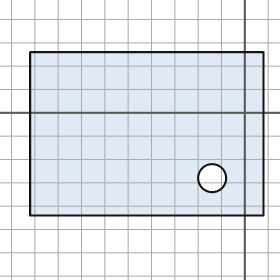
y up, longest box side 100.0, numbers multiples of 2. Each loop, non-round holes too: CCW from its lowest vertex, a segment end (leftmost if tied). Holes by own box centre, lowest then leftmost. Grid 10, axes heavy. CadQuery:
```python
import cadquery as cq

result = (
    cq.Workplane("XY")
    .moveTo(-92.0, -44.0)
    .lineTo(8.0, -44.0)
    .lineTo(8.0, 26.0)
    .lineTo(-92.0, 26.0)
    .close()
    .moveTo(-14.0, -28.0)
    .circle(6.0)
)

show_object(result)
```